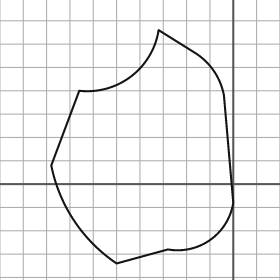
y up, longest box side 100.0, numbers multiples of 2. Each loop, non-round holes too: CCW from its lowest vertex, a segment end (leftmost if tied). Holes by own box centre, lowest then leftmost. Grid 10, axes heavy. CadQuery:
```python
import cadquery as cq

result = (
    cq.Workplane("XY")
    .moveTo(-50.0, -34.0)
    .lineTo(-28.0, -28.0)
    .threePointArc((-10.0, -24.0), (0.0, -8.0))
    .lineTo(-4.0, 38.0)
    .threePointArc((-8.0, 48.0), (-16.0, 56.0))
    .lineTo(-32.0, 66.0)
    .threePointArc((-44.0, 46.0), (-66.0, 40.0))
    .lineTo(-78.0, 8.0)
    .threePointArc((-68.0, -16.0), (-50.0, -34.0))
    .close()
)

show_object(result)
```